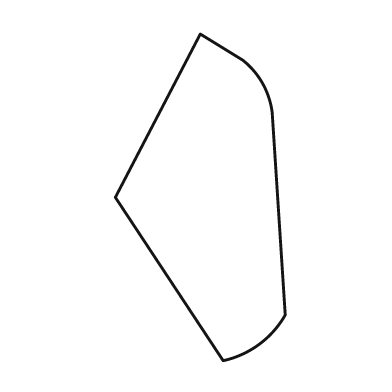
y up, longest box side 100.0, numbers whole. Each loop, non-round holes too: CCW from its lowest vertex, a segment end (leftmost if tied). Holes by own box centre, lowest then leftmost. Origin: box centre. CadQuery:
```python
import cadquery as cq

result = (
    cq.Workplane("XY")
    .moveTo(7.0, -50.0)
    .threePointArc((18.0, -45.0), (26.0, -36.0))
    .lineTo(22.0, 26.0)
    .threePointArc((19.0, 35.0), (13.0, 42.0))
    .lineTo(0.0, 50.0)
    .lineTo(-26.0, 0.0)
    .close()
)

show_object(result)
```